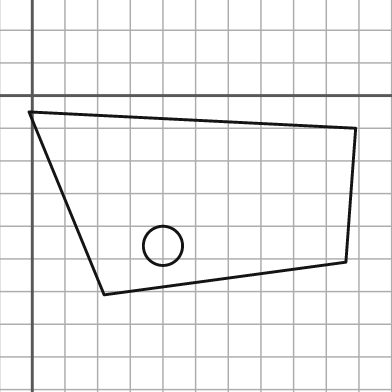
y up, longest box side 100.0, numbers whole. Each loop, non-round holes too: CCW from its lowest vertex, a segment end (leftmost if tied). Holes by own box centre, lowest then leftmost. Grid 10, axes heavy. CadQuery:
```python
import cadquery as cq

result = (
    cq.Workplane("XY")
    .moveTo(22.0, -61.0)
    .lineTo(96.0, -51.0)
    .lineTo(99.0, -10.0)
    .lineTo(-1.0, -5.0)
    .close()
    .moveTo(40.0, -46.0)
    .circle(6.0)
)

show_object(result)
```